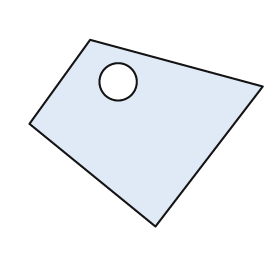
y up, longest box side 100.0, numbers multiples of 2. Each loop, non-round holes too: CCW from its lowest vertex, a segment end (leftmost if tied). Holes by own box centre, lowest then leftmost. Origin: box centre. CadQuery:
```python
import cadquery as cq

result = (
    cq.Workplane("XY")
    .moveTo(4.0, -40.0)
    .lineTo(50.0, 20.0)
    .lineTo(-24.0, 40.0)
    .lineTo(-50.0, 4.0)
    .close()
    .moveTo(-12.0, 22.0)
    .circle(8.0)
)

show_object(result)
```